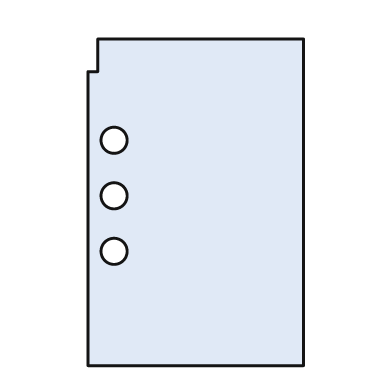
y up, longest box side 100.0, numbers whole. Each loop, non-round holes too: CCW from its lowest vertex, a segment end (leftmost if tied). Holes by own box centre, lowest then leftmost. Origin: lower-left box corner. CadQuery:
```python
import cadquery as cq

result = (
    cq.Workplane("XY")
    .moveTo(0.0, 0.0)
    .lineTo(66.0, 0.0)
    .lineTo(66.0, 100.0)
    .lineTo(3.0, 100.0)
    .lineTo(3.0, 90.0)
    .lineTo(0.0, 90.0)
    .close()
    .moveTo(8.0, 35.0)
    .circle(4.0)
    .moveTo(8.0, 52.0)
    .circle(4.0)
    .moveTo(8.0, 69.0)
    .circle(4.0)
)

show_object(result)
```